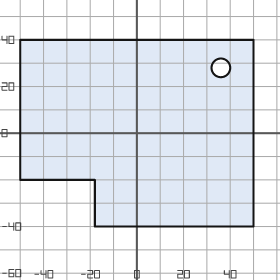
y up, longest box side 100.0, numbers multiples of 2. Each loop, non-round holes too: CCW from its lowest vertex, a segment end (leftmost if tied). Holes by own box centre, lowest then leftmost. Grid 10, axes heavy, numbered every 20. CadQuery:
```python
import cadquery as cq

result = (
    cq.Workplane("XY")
    .moveTo(-18.0, -40.0)
    .lineTo(50.0, -40.0)
    .lineTo(50.0, 40.0)
    .lineTo(-50.0, 40.0)
    .lineTo(-50.0, -20.0)
    .lineTo(-18.0, -20.0)
    .close()
    .moveTo(36.0, 28.0)
    .circle(4.0)
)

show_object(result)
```